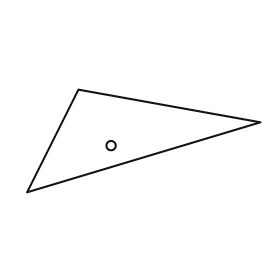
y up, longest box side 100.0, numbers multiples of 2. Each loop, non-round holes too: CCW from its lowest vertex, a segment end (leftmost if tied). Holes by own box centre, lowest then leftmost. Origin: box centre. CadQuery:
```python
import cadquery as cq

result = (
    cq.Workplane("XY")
    .moveTo(-50.0, -22.0)
    .lineTo(50.0, 8.0)
    .lineTo(-28.0, 22.0)
    .close()
    .moveTo(-14.0, -2.0)
    .circle(2.0)
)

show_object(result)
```